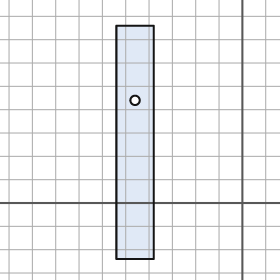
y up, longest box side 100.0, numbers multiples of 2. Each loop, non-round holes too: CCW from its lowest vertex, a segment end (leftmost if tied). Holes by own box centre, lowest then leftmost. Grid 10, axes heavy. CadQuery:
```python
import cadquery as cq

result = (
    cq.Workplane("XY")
    .moveTo(-54.0, -24.0)
    .lineTo(-38.0, -24.0)
    .lineTo(-38.0, 76.0)
    .lineTo(-54.0, 76.0)
    .close()
    .moveTo(-46.0, 44.0)
    .circle(2.0)
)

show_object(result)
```